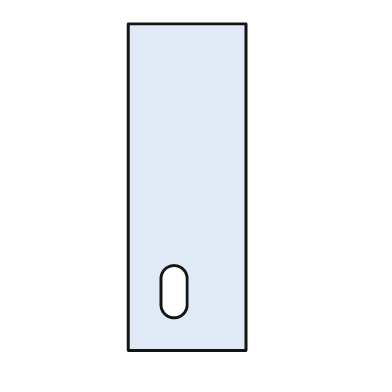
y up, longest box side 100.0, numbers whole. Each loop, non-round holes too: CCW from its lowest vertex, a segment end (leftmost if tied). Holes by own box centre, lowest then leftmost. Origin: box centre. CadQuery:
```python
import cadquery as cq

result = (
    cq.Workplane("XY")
    .moveTo(-18.0, -50.0)
    .lineTo(18.0, -50.0)
    .lineTo(18.0, 50.0)
    .lineTo(-18.0, 50.0)
    .close()
    .moveTo(-8.0, -36.0)
    .threePointArc((-4.0, -40.0), (0.0, -36.0))
    .lineTo(0.0, -28.0)
    .threePointArc((-4.0, -24.0), (-8.0, -28.0))
    .close()
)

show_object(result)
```